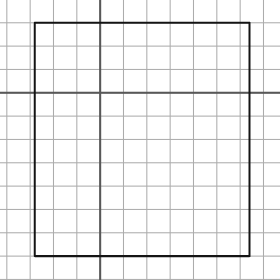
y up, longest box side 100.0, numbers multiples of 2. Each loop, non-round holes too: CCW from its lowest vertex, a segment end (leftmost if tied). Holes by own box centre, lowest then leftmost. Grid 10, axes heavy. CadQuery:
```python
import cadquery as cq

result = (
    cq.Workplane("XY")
    .moveTo(-28.0, -70.0)
    .lineTo(64.0, -70.0)
    .lineTo(64.0, 30.0)
    .lineTo(-28.0, 30.0)
    .close()
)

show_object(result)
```